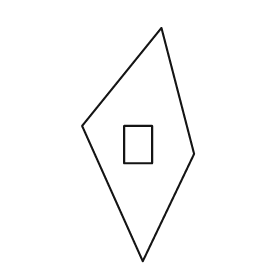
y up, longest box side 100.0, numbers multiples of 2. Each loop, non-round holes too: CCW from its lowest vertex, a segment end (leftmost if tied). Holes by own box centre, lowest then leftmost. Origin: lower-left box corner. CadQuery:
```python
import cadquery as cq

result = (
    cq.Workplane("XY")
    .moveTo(26.0, 0.0)
    .lineTo(48.0, 46.0)
    .lineTo(34.0, 100.0)
    .lineTo(0.0, 58.0)
    .close()
    .moveTo(18.0, 42.0)
    .lineTo(30.0, 42.0)
    .lineTo(30.0, 58.0)
    .lineTo(18.0, 58.0)
    .close()
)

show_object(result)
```